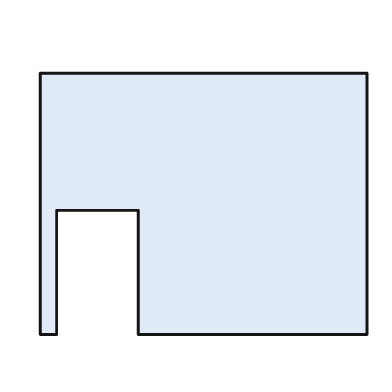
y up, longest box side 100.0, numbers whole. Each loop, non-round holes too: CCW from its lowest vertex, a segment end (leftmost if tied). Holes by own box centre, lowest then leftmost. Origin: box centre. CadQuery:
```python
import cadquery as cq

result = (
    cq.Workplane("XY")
    .moveTo(-50.0, -40.0)
    .lineTo(-45.0, -40.0)
    .lineTo(-45.0, -2.0)
    .lineTo(-20.0, -2.0)
    .lineTo(-20.0, -40.0)
    .lineTo(50.0, -40.0)
    .lineTo(50.0, 40.0)
    .lineTo(-50.0, 40.0)
    .close()
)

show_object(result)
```